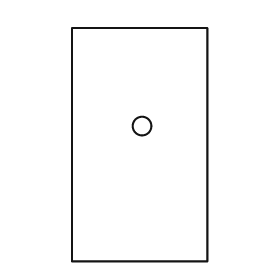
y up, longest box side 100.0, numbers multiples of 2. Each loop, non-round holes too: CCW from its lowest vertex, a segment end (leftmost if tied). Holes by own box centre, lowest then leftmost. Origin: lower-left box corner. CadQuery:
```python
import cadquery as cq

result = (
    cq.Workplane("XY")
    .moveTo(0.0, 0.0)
    .lineTo(58.0, 0.0)
    .lineTo(58.0, 100.0)
    .lineTo(0.0, 100.0)
    .close()
    .moveTo(30.0, 58.0)
    .circle(4.0)
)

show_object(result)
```